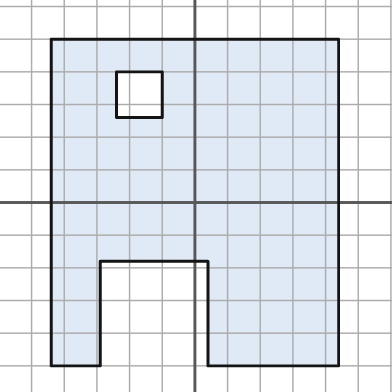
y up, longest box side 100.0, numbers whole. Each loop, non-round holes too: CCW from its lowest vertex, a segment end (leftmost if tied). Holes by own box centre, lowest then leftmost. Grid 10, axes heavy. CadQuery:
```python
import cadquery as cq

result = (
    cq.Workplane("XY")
    .moveTo(-44.0, -50.0)
    .lineTo(-29.0, -50.0)
    .lineTo(-29.0, -18.0)
    .lineTo(4.0, -18.0)
    .lineTo(4.0, -50.0)
    .lineTo(44.0, -50.0)
    .lineTo(44.0, 50.0)
    .lineTo(-44.0, 50.0)
    .close()
    .moveTo(-24.0, 26.0)
    .lineTo(-10.0, 26.0)
    .lineTo(-10.0, 40.0)
    .lineTo(-24.0, 40.0)
    .close()
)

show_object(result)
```